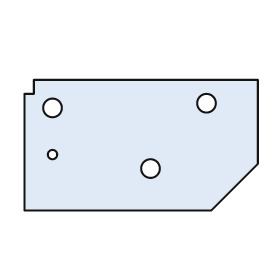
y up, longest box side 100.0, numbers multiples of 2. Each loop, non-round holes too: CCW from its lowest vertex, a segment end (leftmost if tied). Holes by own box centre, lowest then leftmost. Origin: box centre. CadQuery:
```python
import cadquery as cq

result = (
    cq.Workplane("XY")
    .moveTo(-50.0, -28.0)
    .lineTo(30.0, -28.0)
    .lineTo(50.0, -8.0)
    .lineTo(50.0, 28.0)
    .lineTo(-46.0, 28.0)
    .lineTo(-46.0, 22.0)
    .lineTo(-50.0, 22.0)
    .close()
    .moveTo(4.0, -10.0)
    .circle(4.0)
    .moveTo(-38.0, -4.0)
    .circle(2.0)
    .moveTo(-38.0, 16.0)
    .circle(4.0)
    .moveTo(28.0, 18.0)
    .circle(4.0)
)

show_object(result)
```